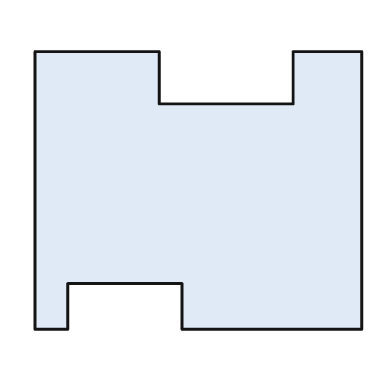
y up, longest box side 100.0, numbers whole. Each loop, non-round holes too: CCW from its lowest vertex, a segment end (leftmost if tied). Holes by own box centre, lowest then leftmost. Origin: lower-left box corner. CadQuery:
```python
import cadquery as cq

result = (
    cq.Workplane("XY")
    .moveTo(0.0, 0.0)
    .lineTo(10.0, 0.0)
    .lineTo(10.0, 14.0)
    .lineTo(45.0, 14.0)
    .lineTo(45.0, 0.0)
    .lineTo(100.0, 0.0)
    .lineTo(100.0, 85.0)
    .lineTo(79.0, 85.0)
    .lineTo(79.0, 69.0)
    .lineTo(38.0, 69.0)
    .lineTo(38.0, 85.0)
    .lineTo(0.0, 85.0)
    .close()
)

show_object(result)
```